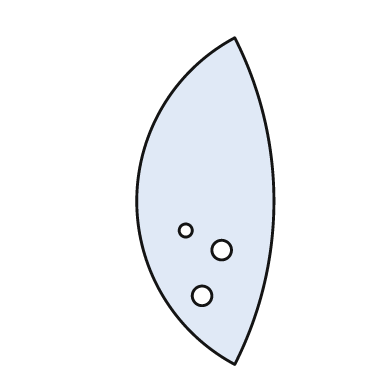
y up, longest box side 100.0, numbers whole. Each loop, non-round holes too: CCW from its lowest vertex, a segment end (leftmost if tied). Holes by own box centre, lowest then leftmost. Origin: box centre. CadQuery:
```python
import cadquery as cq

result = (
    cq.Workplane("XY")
    .moveTo(9.0, -50.0)
    .threePointArc((21.0, 0.0), (9.0, 50.0))
    .threePointArc((-21.0, 0.0), (9.0, -50.0))
    .close()
    .moveTo(-1.0, -29.0)
    .circle(3.0)
    .moveTo(5.0, -15.0)
    .circle(3.0)
    .moveTo(-6.0, -9.0)
    .circle(2.0)
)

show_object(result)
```